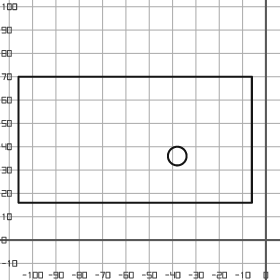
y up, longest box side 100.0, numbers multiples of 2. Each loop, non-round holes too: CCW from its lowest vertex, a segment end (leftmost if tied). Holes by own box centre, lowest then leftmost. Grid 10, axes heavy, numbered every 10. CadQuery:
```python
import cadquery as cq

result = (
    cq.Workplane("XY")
    .moveTo(-106.0, 16.0)
    .lineTo(-6.0, 16.0)
    .lineTo(-6.0, 70.0)
    .lineTo(-106.0, 70.0)
    .close()
    .moveTo(-38.0, 36.0)
    .circle(4.0)
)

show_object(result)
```